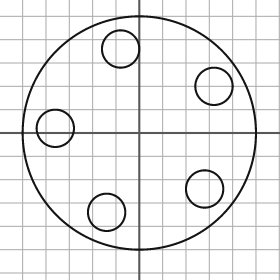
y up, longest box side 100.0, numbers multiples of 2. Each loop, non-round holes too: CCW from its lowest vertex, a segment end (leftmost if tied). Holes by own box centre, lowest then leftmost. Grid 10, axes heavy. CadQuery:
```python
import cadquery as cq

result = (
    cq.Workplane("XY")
    .moveTo(0.0, 0.0)
    .circle(50.0)
    .moveTo(-14.0, -34.0)
    .circle(8.0)
    .moveTo(28.0, -24.0)
    .circle(8.0)
    .moveTo(-36.0, 2.0)
    .circle(8.0)
    .moveTo(32.0, 20.0)
    .circle(8.0)
    .moveTo(-8.0, 36.0)
    .circle(8.0)
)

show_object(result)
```